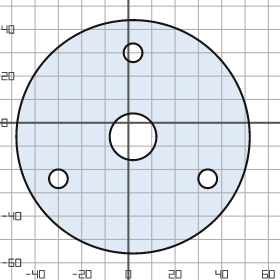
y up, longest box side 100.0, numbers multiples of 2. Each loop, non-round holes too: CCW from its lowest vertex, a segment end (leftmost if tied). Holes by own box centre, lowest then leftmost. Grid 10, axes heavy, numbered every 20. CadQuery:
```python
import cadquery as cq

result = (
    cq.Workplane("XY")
    .moveTo(2.0, -6.0)
    .circle(50.0)
    .moveTo(-30.0, -24.0)
    .circle(4.0)
    .moveTo(34.0, -24.0)
    .circle(4.0)
    .moveTo(2.0, -6.0)
    .circle(10.0)
    .moveTo(2.0, 30.0)
    .circle(4.0)
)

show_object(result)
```